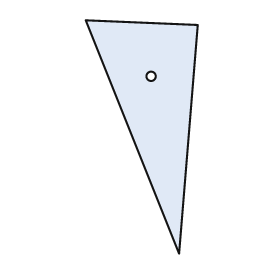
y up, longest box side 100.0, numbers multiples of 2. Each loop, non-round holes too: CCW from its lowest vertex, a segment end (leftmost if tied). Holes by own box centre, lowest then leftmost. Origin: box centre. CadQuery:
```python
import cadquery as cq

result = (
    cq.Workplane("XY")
    .moveTo(16.0, -50.0)
    .lineTo(24.0, 48.0)
    .lineTo(-24.0, 50.0)
    .close()
    .moveTo(4.0, 26.0)
    .circle(2.0)
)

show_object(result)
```